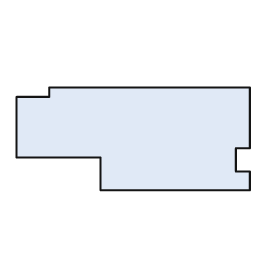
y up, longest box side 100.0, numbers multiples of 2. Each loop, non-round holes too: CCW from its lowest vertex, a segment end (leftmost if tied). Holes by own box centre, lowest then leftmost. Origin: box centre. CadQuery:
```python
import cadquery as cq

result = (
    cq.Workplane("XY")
    .moveTo(-14.0, -22.0)
    .lineTo(50.0, -22.0)
    .lineTo(50.0, -14.0)
    .lineTo(44.0, -14.0)
    .lineTo(44.0, -4.0)
    .lineTo(50.0, -4.0)
    .lineTo(50.0, 22.0)
    .lineTo(-36.0, 22.0)
    .lineTo(-36.0, 18.0)
    .lineTo(-50.0, 18.0)
    .lineTo(-50.0, -8.0)
    .lineTo(-14.0, -8.0)
    .close()
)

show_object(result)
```